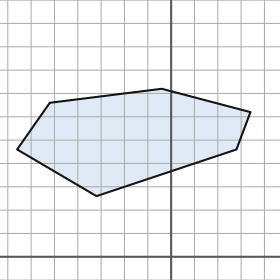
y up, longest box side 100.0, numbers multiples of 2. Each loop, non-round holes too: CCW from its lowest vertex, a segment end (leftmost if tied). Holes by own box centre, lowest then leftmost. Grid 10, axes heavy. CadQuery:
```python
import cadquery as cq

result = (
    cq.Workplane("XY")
    .moveTo(-32.0, 26.0)
    .lineTo(28.0, 46.0)
    .lineTo(34.0, 62.0)
    .lineTo(-4.0, 72.0)
    .lineTo(-52.0, 66.0)
    .lineTo(-66.0, 46.0)
    .close()
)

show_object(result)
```